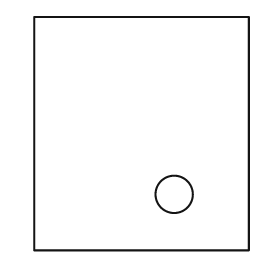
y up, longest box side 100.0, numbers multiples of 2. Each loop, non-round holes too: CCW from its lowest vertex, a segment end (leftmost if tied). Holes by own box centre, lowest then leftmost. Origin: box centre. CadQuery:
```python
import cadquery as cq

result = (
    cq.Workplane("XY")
    .moveTo(-46.0, -50.0)
    .lineTo(46.0, -50.0)
    .lineTo(46.0, 50.0)
    .lineTo(-46.0, 50.0)
    .close()
    .moveTo(14.0, -26.0)
    .circle(8.0)
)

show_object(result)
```